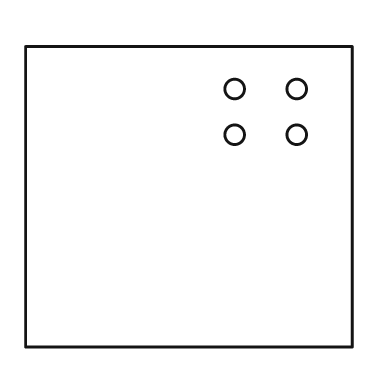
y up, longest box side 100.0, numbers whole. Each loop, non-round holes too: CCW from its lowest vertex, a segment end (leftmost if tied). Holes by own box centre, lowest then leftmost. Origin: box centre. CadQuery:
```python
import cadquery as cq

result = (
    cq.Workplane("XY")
    .moveTo(-50.0, -46.0)
    .lineTo(50.0, -46.0)
    .lineTo(50.0, 46.0)
    .lineTo(-50.0, 46.0)
    .close()
    .moveTo(14.0, 19.0)
    .circle(3.0)
    .moveTo(33.0, 19.0)
    .circle(3.0)
    .moveTo(14.0, 33.0)
    .circle(3.0)
    .moveTo(33.0, 33.0)
    .circle(3.0)
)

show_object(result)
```